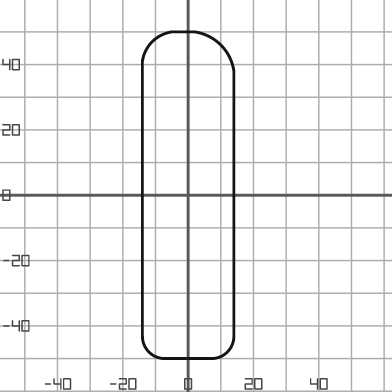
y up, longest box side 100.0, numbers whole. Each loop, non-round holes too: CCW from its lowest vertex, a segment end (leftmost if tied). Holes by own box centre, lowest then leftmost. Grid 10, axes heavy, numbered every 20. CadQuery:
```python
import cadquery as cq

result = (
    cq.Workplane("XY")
    .moveTo(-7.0, -50.0)
    .lineTo(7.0, -50.0)
    .threePointArc((12.0, -48.0), (14.0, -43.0))
    .lineTo(14.0, 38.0)
    .threePointArc((10.0, 46.0), (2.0, 50.0))
    .lineTo(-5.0, 50.0)
    .threePointArc((-11.0, 47.0), (-14.0, 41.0))
    .lineTo(-14.0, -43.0)
    .threePointArc((-12.0, -48.0), (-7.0, -50.0))
    .close()
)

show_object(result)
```